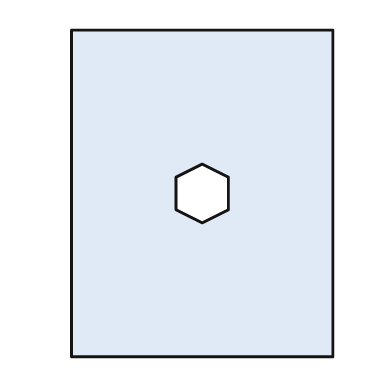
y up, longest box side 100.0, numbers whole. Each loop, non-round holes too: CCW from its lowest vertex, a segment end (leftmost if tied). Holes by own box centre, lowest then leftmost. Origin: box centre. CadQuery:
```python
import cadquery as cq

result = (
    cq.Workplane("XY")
    .moveTo(-40.0, -50.0)
    .lineTo(40.0, -50.0)
    .lineTo(40.0, 50.0)
    .lineTo(-40.0, 50.0)
    .close()
    .moveTo(0.0, -9.0)
    .lineTo(8.0, -5.0)
    .lineTo(8.0, 5.0)
    .lineTo(0.0, 9.0)
    .lineTo(-8.0, 5.0)
    .lineTo(-8.0, -5.0)
    .close()
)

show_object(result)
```